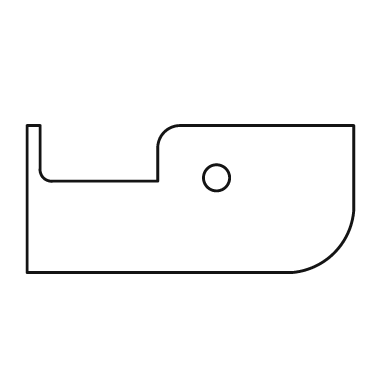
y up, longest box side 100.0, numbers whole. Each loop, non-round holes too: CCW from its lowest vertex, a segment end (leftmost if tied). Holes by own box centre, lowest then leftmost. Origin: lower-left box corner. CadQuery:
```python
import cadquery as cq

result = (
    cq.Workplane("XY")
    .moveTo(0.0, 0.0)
    .lineTo(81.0, 0.0)
    .threePointArc((94.0, 6.0), (100.0, 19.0))
    .lineTo(100.0, 45.0)
    .lineTo(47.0, 45.0)
    .threePointArc((42.0, 43.0), (40.0, 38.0))
    .lineTo(40.0, 28.0)
    .lineTo(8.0, 28.0)
    .threePointArc((5.0, 29.0), (4.0, 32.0))
    .lineTo(4.0, 45.0)
    .lineTo(0.0, 45.0)
    .close()
    .moveTo(58.0, 29.0)
    .circle(4.0)
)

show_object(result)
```